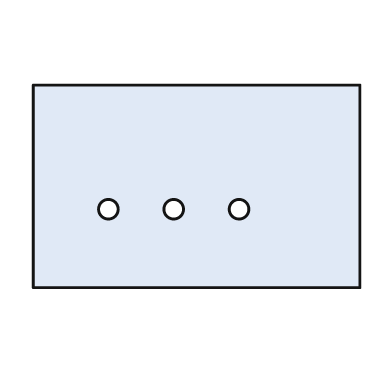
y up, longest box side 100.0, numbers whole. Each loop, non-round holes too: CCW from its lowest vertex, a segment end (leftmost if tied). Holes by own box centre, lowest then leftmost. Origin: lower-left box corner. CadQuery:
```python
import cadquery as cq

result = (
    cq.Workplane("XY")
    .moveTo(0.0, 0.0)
    .lineTo(100.0, 0.0)
    .lineTo(100.0, 62.0)
    .lineTo(0.0, 62.0)
    .close()
    .moveTo(23.0, 24.0)
    .circle(3.0)
    .moveTo(43.0, 24.0)
    .circle(3.0)
    .moveTo(63.0, 24.0)
    .circle(3.0)
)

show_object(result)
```